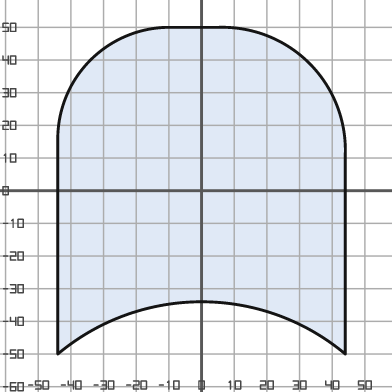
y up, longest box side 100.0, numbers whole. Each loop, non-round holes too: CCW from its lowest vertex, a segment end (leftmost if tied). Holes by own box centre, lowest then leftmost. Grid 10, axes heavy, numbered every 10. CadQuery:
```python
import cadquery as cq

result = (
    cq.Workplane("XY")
    .moveTo(-44.0, -50.0)
    .threePointArc((0.0, -34.0), (44.0, -50.0))
    .lineTo(44.0, 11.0)
    .threePointArc((33.0, 39.0), (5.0, 50.0))
    .lineTo(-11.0, 50.0)
    .threePointArc((-34.0, 40.0), (-44.0, 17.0))
    .close()
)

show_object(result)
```